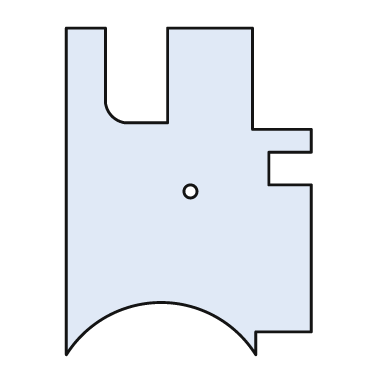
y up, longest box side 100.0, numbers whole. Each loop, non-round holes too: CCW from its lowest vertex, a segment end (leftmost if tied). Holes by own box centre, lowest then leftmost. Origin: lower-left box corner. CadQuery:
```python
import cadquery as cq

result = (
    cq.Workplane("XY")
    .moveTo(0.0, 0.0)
    .threePointArc((29.0, 16.0), (58.0, 0.0))
    .lineTo(58.0, 7.0)
    .lineTo(75.0, 7.0)
    .lineTo(75.0, 52.0)
    .lineTo(62.0, 52.0)
    .lineTo(62.0, 62.0)
    .lineTo(75.0, 62.0)
    .lineTo(75.0, 69.0)
    .lineTo(57.0, 69.0)
    .lineTo(57.0, 100.0)
    .lineTo(31.0, 100.0)
    .lineTo(31.0, 71.0)
    .lineTo(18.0, 71.0)
    .threePointArc((14.0, 73.0), (12.0, 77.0))
    .lineTo(12.0, 100.0)
    .lineTo(0.0, 100.0)
    .close()
    .moveTo(38.0, 50.0)
    .circle(2.0)
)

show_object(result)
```